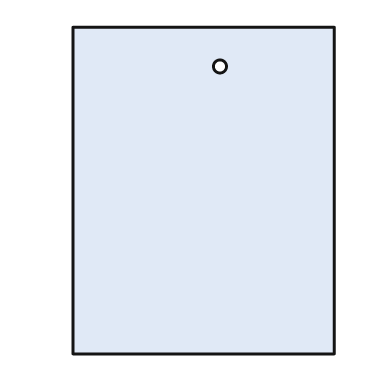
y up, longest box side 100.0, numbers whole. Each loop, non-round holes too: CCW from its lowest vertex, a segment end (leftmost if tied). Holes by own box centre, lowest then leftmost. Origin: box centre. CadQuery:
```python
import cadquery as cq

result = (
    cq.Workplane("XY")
    .moveTo(-40.0, -50.0)
    .lineTo(40.0, -50.0)
    .lineTo(40.0, 50.0)
    .lineTo(-40.0, 50.0)
    .close()
    .moveTo(5.0, 38.0)
    .circle(2.0)
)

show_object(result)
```